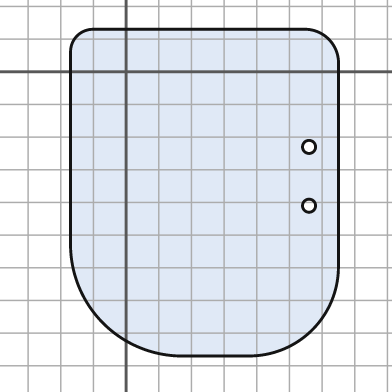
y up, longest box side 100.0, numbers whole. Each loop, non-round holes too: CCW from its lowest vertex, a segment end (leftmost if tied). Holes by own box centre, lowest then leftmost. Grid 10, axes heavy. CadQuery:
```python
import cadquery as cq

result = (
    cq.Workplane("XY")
    .moveTo(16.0, -87.0)
    .lineTo(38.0, -87.0)
    .threePointArc((57.0, -79.0), (65.0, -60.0))
    .lineTo(65.0, 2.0)
    .threePointArc((62.0, 10.0), (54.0, 13.0))
    .lineTo(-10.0, 13.0)
    .threePointArc((-15.0, 11.0), (-17.0, 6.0))
    .lineTo(-17.0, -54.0)
    .threePointArc((-7.0, -77.0), (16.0, -87.0))
    .close()
    .moveTo(56.0, -41.0)
    .circle(2.0)
    .moveTo(56.0, -23.0)
    .circle(2.0)
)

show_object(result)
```